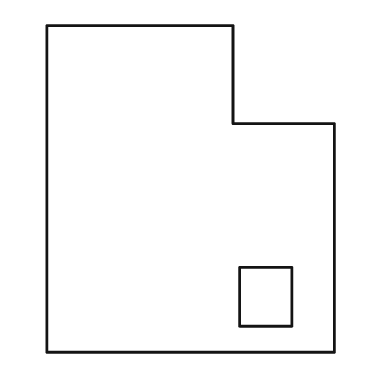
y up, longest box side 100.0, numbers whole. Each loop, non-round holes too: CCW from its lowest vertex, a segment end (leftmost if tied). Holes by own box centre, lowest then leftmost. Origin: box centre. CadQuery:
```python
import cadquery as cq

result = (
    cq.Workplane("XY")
    .moveTo(-44.0, -50.0)
    .lineTo(44.0, -50.0)
    .lineTo(44.0, 20.0)
    .lineTo(13.0, 20.0)
    .lineTo(13.0, 50.0)
    .lineTo(-44.0, 50.0)
    .close()
    .moveTo(15.0, -42.0)
    .lineTo(31.0, -42.0)
    .lineTo(31.0, -24.0)
    .lineTo(15.0, -24.0)
    .close()
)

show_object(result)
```